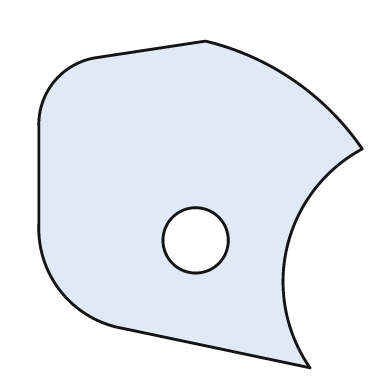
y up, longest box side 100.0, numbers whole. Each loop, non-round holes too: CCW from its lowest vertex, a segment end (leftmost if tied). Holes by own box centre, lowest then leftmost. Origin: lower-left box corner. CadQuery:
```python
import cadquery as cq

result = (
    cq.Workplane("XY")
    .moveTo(83.0, 0.0)
    .threePointArc((76.0, 37.0), (99.0, 67.0))
    .threePointArc((78.0, 88.0), (51.0, 100.0))
    .lineTo(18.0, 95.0)
    .threePointArc((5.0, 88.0), (0.0, 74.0))
    .lineTo(0.0, 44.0)
    .threePointArc((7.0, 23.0), (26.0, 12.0))
    .close()
    .moveTo(48.0, 39.0)
    .circle(10.0)
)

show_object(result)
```